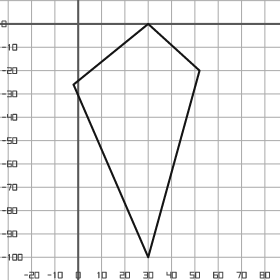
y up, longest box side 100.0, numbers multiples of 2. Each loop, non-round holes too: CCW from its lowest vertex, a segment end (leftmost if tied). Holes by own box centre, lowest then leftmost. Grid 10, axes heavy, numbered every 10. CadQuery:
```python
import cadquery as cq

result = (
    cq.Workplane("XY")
    .moveTo(30.0, -100.0)
    .lineTo(52.0, -20.0)
    .lineTo(30.0, 0.0)
    .lineTo(-2.0, -26.0)
    .close()
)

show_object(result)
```